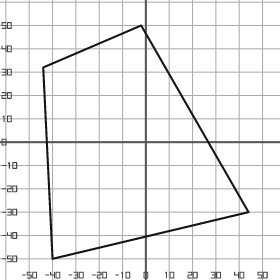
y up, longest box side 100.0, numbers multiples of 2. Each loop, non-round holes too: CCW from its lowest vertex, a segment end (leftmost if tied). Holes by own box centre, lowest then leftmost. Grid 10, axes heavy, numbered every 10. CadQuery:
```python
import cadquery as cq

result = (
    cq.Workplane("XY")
    .moveTo(-40.0, -50.0)
    .lineTo(44.0, -30.0)
    .lineTo(-2.0, 50.0)
    .lineTo(-44.0, 32.0)
    .close()
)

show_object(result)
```